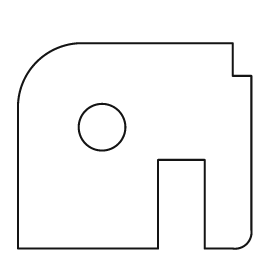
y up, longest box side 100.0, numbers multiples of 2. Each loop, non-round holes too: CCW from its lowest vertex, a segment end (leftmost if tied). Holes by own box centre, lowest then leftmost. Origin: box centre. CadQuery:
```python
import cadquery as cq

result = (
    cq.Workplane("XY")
    .moveTo(-50.0, -44.0)
    .lineTo(10.0, -44.0)
    .lineTo(10.0, -6.0)
    .lineTo(30.0, -6.0)
    .lineTo(30.0, -44.0)
    .lineTo(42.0, -44.0)
    .threePointArc((48.0, -42.0), (50.0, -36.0))
    .lineTo(50.0, 30.0)
    .lineTo(42.0, 30.0)
    .lineTo(42.0, 44.0)
    .lineTo(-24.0, 44.0)
    .threePointArc((-42.0, 36.0), (-50.0, 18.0))
    .close()
    .moveTo(-14.0, 8.0)
    .circle(10.0)
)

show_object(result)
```